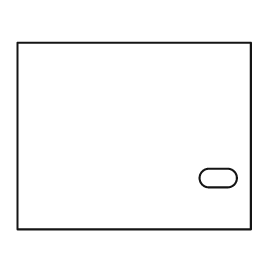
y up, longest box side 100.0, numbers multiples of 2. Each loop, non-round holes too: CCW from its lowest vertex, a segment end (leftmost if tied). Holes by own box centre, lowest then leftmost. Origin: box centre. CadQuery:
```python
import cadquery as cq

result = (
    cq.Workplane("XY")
    .moveTo(-50.0, -40.0)
    .lineTo(50.0, -40.0)
    .lineTo(50.0, 40.0)
    .lineTo(-50.0, 40.0)
    .close()
    .moveTo(32.0, -22.0)
    .lineTo(40.0, -22.0)
    .threePointArc((44.0, -18.0), (40.0, -14.0))
    .lineTo(32.0, -14.0)
    .threePointArc((28.0, -18.0), (32.0, -22.0))
    .close()
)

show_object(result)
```